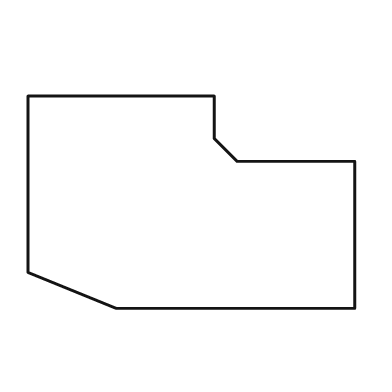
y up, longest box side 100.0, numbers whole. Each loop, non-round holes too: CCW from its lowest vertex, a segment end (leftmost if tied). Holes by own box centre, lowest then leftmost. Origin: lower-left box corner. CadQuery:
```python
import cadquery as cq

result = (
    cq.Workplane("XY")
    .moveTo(27.0, 0.0)
    .lineTo(100.0, 0.0)
    .lineTo(100.0, 45.0)
    .lineTo(64.0, 45.0)
    .lineTo(57.0, 52.0)
    .lineTo(57.0, 65.0)
    .lineTo(0.0, 65.0)
    .lineTo(0.0, 11.0)
    .close()
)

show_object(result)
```